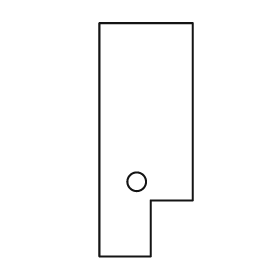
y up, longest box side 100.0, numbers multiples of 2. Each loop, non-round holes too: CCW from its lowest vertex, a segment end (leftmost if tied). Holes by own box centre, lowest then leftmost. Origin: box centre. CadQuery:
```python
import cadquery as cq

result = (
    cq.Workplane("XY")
    .moveTo(-20.0, -50.0)
    .lineTo(2.0, -50.0)
    .lineTo(2.0, -26.0)
    .lineTo(20.0, -26.0)
    .lineTo(20.0, 50.0)
    .lineTo(-20.0, 50.0)
    .close()
    .moveTo(-4.0, -18.0)
    .circle(4.0)
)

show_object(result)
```